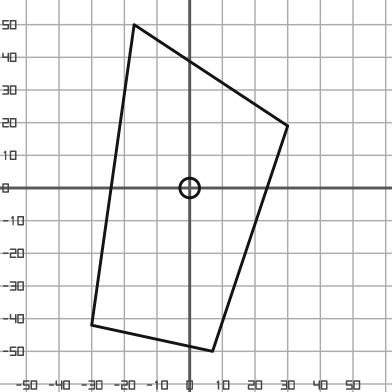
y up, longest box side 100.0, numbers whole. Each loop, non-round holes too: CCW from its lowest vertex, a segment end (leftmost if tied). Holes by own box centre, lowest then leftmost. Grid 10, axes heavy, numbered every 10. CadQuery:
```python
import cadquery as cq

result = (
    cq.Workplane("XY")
    .moveTo(7.0, -50.0)
    .lineTo(30.0, 19.0)
    .lineTo(-17.0, 50.0)
    .lineTo(-30.0, -42.0)
    .close()
    .moveTo(0.0, 0.0)
    .circle(3.0)
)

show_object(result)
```